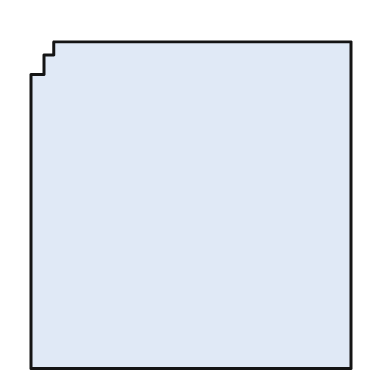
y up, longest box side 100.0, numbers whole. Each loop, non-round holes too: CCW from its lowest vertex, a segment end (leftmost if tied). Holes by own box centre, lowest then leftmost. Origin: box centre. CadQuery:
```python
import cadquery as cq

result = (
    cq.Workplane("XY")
    .moveTo(-49.0, -50.0)
    .lineTo(49.0, -50.0)
    .lineTo(49.0, 50.0)
    .lineTo(-42.0, 50.0)
    .lineTo(-42.0, 46.0)
    .lineTo(-45.0, 46.0)
    .lineTo(-45.0, 40.0)
    .lineTo(-49.0, 40.0)
    .close()
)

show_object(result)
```